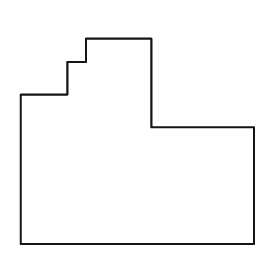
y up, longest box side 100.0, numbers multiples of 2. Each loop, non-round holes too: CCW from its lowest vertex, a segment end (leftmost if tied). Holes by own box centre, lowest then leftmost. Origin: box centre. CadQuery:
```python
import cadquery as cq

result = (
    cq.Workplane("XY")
    .moveTo(-50.0, -44.0)
    .lineTo(50.0, -44.0)
    .lineTo(50.0, 6.0)
    .lineTo(6.0, 6.0)
    .lineTo(6.0, 44.0)
    .lineTo(-22.0, 44.0)
    .lineTo(-22.0, 34.0)
    .lineTo(-30.0, 34.0)
    .lineTo(-30.0, 20.0)
    .lineTo(-50.0, 20.0)
    .close()
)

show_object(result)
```